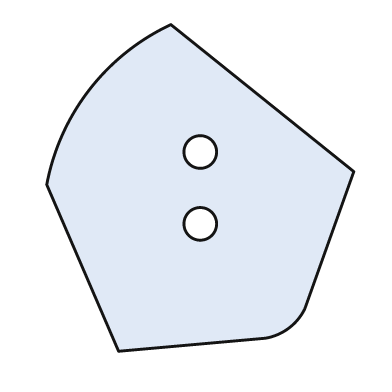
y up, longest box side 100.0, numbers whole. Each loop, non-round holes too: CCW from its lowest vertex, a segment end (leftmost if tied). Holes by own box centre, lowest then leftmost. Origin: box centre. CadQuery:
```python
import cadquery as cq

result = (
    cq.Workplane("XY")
    .moveTo(-25.0, -50.0)
    .lineTo(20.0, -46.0)
    .threePointArc((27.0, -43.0), (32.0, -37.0))
    .lineTo(47.0, 5.0)
    .lineTo(-9.0, 50.0)
    .threePointArc((-34.0, 30.0), (-47.0, 1.0))
    .close()
    .moveTo(0.0, -11.0)
    .circle(5.0)
    .moveTo(0.0, 11.0)
    .circle(5.0)
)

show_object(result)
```